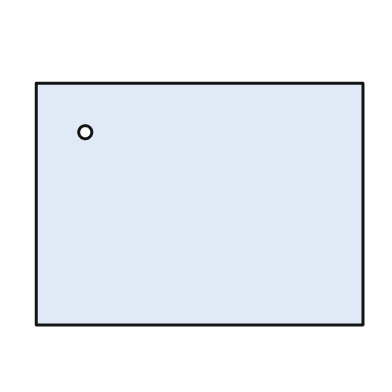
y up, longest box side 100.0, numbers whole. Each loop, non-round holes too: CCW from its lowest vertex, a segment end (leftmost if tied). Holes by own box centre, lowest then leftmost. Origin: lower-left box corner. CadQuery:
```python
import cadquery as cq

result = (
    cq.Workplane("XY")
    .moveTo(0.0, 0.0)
    .lineTo(100.0, 0.0)
    .lineTo(100.0, 74.0)
    .lineTo(0.0, 74.0)
    .close()
    .moveTo(15.0, 59.0)
    .circle(2.0)
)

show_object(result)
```